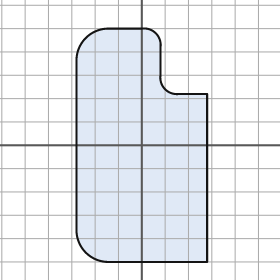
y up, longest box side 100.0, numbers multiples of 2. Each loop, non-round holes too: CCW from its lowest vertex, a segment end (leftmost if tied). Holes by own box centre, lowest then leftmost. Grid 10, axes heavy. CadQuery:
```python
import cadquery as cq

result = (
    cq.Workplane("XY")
    .moveTo(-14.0, -50.0)
    .lineTo(28.0, -50.0)
    .lineTo(28.0, 22.0)
    .lineTo(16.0, 22.0)
    .threePointArc((10.0, 24.0), (8.0, 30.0))
    .lineTo(8.0, 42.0)
    .threePointArc((6.0, 48.0), (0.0, 50.0))
    .lineTo(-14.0, 50.0)
    .threePointArc((-24.0, 46.0), (-28.0, 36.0))
    .lineTo(-28.0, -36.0)
    .threePointArc((-24.0, -46.0), (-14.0, -50.0))
    .close()
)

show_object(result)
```